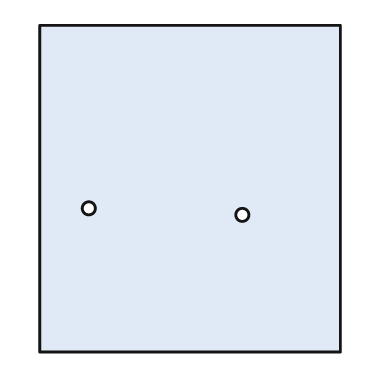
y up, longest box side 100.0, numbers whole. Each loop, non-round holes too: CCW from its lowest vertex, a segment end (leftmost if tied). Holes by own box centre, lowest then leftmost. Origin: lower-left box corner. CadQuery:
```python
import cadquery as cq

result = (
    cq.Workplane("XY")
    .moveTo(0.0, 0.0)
    .lineTo(92.0, 0.0)
    .lineTo(92.0, 100.0)
    .lineTo(0.0, 100.0)
    .close()
    .moveTo(62.0, 42.0)
    .circle(2.0)
    .moveTo(15.0, 44.0)
    .circle(2.0)
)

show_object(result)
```